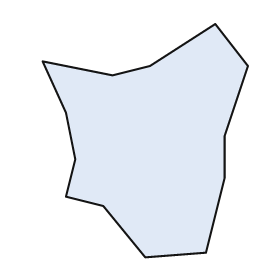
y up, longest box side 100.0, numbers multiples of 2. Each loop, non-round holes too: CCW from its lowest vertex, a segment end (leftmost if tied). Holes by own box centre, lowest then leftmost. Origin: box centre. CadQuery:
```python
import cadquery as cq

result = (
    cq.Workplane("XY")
    .moveTo(0.0, -50.0)
    .lineTo(26.0, -48.0)
    .lineTo(34.0, -16.0)
    .lineTo(34.0, 2.0)
    .lineTo(44.0, 32.0)
    .lineTo(30.0, 50.0)
    .lineTo(2.0, 32.0)
    .lineTo(-14.0, 28.0)
    .lineTo(-44.0, 34.0)
    .lineTo(-34.0, 12.0)
    .lineTo(-30.0, -8.0)
    .lineTo(-34.0, -24.0)
    .lineTo(-18.0, -28.0)
    .close()
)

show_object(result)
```